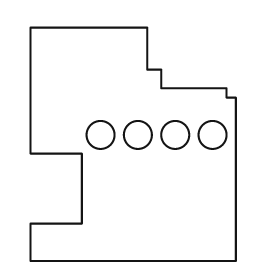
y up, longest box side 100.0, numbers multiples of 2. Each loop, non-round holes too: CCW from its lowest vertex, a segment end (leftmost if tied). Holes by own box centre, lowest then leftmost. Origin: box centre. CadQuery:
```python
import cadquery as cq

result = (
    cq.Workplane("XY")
    .moveTo(-44.0, -50.0)
    .lineTo(44.0, -50.0)
    .lineTo(44.0, 20.0)
    .lineTo(40.0, 20.0)
    .lineTo(40.0, 24.0)
    .lineTo(12.0, 24.0)
    .lineTo(12.0, 32.0)
    .lineTo(6.0, 32.0)
    .lineTo(6.0, 50.0)
    .lineTo(-44.0, 50.0)
    .lineTo(-44.0, -4.0)
    .lineTo(-22.0, -4.0)
    .lineTo(-22.0, -34.0)
    .lineTo(-44.0, -34.0)
    .close()
    .moveTo(-14.0, 4.0)
    .circle(6.0)
    .moveTo(2.0, 4.0)
    .circle(6.0)
    .moveTo(18.0, 4.0)
    .circle(6.0)
    .moveTo(34.0, 4.0)
    .circle(6.0)
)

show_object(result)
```